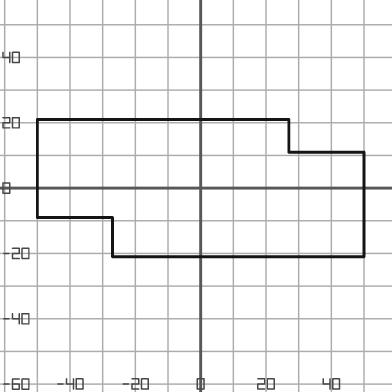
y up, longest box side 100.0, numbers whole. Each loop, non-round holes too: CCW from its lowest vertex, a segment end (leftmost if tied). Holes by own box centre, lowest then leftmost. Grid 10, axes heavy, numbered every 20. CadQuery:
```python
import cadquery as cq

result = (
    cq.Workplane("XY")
    .moveTo(-27.0, -21.0)
    .lineTo(50.0, -21.0)
    .lineTo(50.0, 11.0)
    .lineTo(27.0, 11.0)
    .lineTo(27.0, 21.0)
    .lineTo(-50.0, 21.0)
    .lineTo(-50.0, -9.0)
    .lineTo(-27.0, -9.0)
    .close()
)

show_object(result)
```